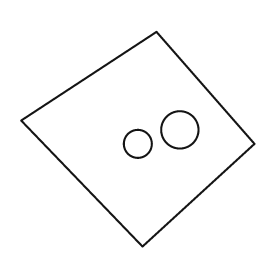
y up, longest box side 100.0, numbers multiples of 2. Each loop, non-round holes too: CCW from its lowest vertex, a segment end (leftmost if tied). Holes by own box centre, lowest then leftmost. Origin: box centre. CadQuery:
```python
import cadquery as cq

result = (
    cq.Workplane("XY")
    .moveTo(2.0, -46.0)
    .lineTo(50.0, -2.0)
    .lineTo(8.0, 46.0)
    .lineTo(-50.0, 8.0)
    .close()
    .moveTo(0.0, -2.0)
    .circle(6.0)
    .moveTo(18.0, 4.0)
    .circle(8.0)
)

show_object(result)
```